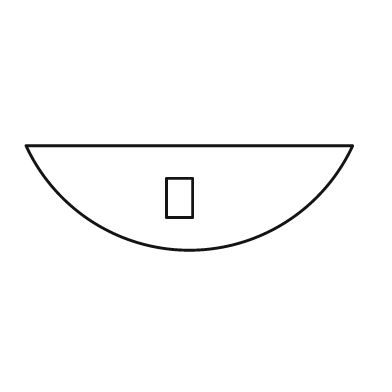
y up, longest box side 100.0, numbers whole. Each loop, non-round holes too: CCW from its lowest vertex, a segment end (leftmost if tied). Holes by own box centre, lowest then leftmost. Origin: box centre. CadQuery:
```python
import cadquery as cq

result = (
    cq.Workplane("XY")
    .moveTo(-50.0, 16.0)
    .threePointArc((0.0, -16.0), (50.0, 16.0))
    .close()
    .moveTo(-7.0, -6.0)
    .lineTo(1.0, -6.0)
    .lineTo(1.0, 6.0)
    .lineTo(-7.0, 6.0)
    .close()
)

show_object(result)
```